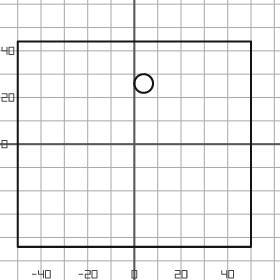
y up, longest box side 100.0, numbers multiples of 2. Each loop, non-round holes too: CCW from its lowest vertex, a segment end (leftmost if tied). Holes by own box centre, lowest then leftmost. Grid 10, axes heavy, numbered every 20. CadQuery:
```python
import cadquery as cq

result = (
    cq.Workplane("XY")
    .moveTo(-50.0, -44.0)
    .lineTo(50.0, -44.0)
    .lineTo(50.0, 44.0)
    .lineTo(-50.0, 44.0)
    .close()
    .moveTo(4.0, 26.0)
    .circle(4.0)
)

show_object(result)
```